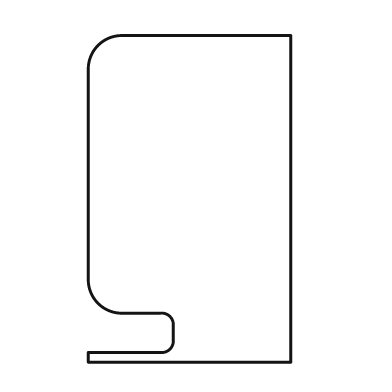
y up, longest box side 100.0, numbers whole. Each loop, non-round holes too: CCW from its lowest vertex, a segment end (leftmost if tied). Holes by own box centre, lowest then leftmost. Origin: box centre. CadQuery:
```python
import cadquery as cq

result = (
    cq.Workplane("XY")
    .moveTo(-31.0, -50.0)
    .lineTo(31.0, -50.0)
    .lineTo(31.0, 50.0)
    .lineTo(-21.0, 50.0)
    .threePointArc((-28.0, 47.0), (-31.0, 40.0))
    .lineTo(-31.0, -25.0)
    .threePointArc((-28.0, -32.0), (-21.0, -35.0))
    .lineTo(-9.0, -35.0)
    .threePointArc((-6.0, -36.0), (-5.0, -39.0))
    .lineTo(-5.0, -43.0)
    .threePointArc((-6.0, -46.0), (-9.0, -47.0))
    .lineTo(-31.0, -47.0)
    .close()
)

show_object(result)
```